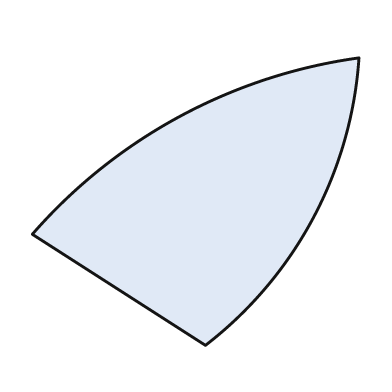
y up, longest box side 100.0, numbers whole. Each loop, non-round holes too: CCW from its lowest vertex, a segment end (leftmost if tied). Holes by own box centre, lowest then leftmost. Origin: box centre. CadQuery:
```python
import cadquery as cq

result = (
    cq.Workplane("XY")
    .moveTo(3.0, -44.0)
    .threePointArc((36.0, -5.0), (50.0, 44.0))
    .threePointArc((-5.0, 26.0), (-50.0, -10.0))
    .close()
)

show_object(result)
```